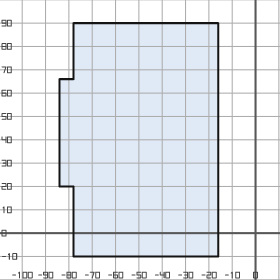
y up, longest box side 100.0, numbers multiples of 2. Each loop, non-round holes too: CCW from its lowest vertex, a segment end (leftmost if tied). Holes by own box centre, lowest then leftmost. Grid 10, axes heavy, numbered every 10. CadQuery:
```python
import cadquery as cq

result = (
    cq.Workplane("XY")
    .moveTo(-78.0, -10.0)
    .lineTo(-16.0, -10.0)
    .lineTo(-16.0, 90.0)
    .lineTo(-78.0, 90.0)
    .lineTo(-78.0, 66.0)
    .lineTo(-84.0, 66.0)
    .lineTo(-84.0, 20.0)
    .lineTo(-78.0, 20.0)
    .close()
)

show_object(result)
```